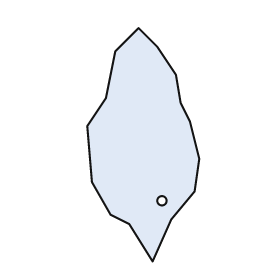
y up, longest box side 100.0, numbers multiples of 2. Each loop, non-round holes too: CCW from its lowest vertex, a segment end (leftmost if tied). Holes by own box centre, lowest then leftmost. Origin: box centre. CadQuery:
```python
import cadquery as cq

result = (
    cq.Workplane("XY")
    .moveTo(4.0, -50.0)
    .lineTo(12.0, -32.0)
    .lineTo(22.0, -20.0)
    .lineTo(24.0, -6.0)
    .lineTo(20.0, 10.0)
    .lineTo(16.0, 18.0)
    .lineTo(14.0, 30.0)
    .lineTo(6.0, 42.0)
    .lineTo(-2.0, 50.0)
    .lineTo(-12.0, 40.0)
    .lineTo(-16.0, 20.0)
    .lineTo(-24.0, 8.0)
    .lineTo(-22.0, -16.0)
    .lineTo(-14.0, -30.0)
    .lineTo(-6.0, -34.0)
    .close()
    .moveTo(8.0, -24.0)
    .circle(2.0)
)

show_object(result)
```